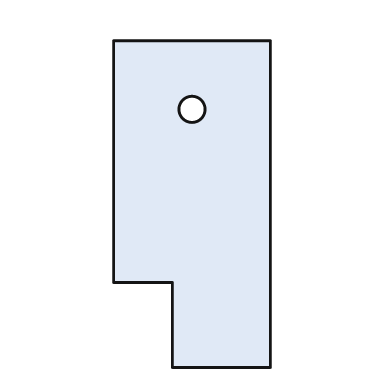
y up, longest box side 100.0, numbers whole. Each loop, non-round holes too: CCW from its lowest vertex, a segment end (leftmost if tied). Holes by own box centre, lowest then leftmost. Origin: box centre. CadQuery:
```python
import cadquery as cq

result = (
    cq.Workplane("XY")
    .moveTo(-6.0, -50.0)
    .lineTo(24.0, -50.0)
    .lineTo(24.0, 50.0)
    .lineTo(-24.0, 50.0)
    .lineTo(-24.0, -24.0)
    .lineTo(-6.0, -24.0)
    .close()
    .moveTo(0.0, 29.0)
    .circle(4.0)
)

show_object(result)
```